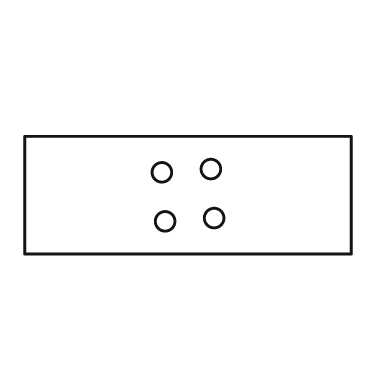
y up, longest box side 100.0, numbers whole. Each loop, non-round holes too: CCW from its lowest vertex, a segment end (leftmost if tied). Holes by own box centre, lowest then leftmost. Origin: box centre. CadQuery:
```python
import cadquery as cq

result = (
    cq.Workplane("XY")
    .moveTo(-50.0, -18.0)
    .lineTo(50.0, -18.0)
    .lineTo(50.0, 18.0)
    .lineTo(-50.0, 18.0)
    .close()
    .moveTo(-7.0, -8.0)
    .circle(3.0)
    .moveTo(8.0, -7.0)
    .circle(3.0)
    .moveTo(-8.0, 7.0)
    .circle(3.0)
    .moveTo(7.0, 8.0)
    .circle(3.0)
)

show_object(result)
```